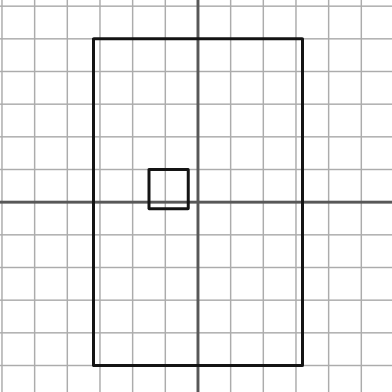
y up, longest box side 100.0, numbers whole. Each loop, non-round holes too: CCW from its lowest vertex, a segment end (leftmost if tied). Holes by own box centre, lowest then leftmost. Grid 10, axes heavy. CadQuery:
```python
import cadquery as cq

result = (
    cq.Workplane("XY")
    .moveTo(-32.0, -50.0)
    .lineTo(32.0, -50.0)
    .lineTo(32.0, 50.0)
    .lineTo(-32.0, 50.0)
    .close()
    .moveTo(-15.0, -2.0)
    .lineTo(-3.0, -2.0)
    .lineTo(-3.0, 10.0)
    .lineTo(-15.0, 10.0)
    .close()
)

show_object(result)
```